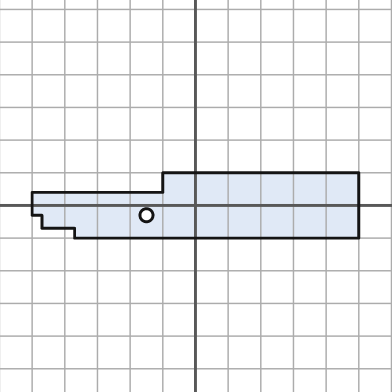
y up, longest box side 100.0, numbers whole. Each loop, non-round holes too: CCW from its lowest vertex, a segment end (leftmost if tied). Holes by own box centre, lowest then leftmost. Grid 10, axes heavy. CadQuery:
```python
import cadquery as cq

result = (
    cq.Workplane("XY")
    .moveTo(-37.0, -10.0)
    .lineTo(50.0, -10.0)
    .lineTo(50.0, 10.0)
    .lineTo(-10.0, 10.0)
    .lineTo(-10.0, 4.0)
    .lineTo(-50.0, 4.0)
    .lineTo(-50.0, -3.0)
    .lineTo(-47.0, -3.0)
    .lineTo(-47.0, -7.0)
    .lineTo(-37.0, -7.0)
    .close()
    .moveTo(-15.0, -3.0)
    .circle(2.0)
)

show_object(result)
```